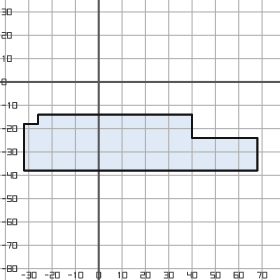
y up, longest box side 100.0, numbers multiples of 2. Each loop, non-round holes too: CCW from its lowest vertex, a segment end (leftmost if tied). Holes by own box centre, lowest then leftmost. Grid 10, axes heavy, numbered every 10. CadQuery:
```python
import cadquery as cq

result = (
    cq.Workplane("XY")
    .moveTo(-32.0, -38.0)
    .lineTo(68.0, -38.0)
    .lineTo(68.0, -24.0)
    .lineTo(40.0, -24.0)
    .lineTo(40.0, -14.0)
    .lineTo(-26.0, -14.0)
    .lineTo(-26.0, -18.0)
    .lineTo(-32.0, -18.0)
    .close()
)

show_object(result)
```